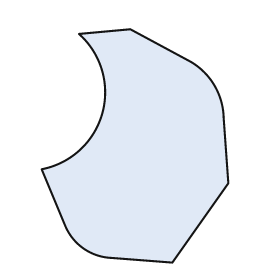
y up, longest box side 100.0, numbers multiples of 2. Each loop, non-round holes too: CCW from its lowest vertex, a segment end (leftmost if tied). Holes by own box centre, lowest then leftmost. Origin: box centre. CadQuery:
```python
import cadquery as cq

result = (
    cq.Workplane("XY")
    .moveTo(16.0, -50.0)
    .lineTo(40.0, -16.0)
    .lineTo(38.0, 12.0)
    .threePointArc((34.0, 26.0), (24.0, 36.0))
    .lineTo(-2.0, 50.0)
    .lineTo(-24.0, 48.0)
    .threePointArc((-14.0, 14.0), (-40.0, -10.0))
    .lineTo(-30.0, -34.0)
    .threePointArc((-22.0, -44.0), (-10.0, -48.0))
    .close()
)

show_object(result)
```